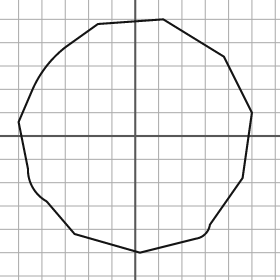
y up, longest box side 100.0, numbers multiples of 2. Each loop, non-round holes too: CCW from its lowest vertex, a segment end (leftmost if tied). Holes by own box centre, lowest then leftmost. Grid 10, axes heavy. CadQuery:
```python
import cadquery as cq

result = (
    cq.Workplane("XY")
    .moveTo(2.0, -50.0)
    .lineTo(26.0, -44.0)
    .threePointArc((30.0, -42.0), (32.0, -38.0))
    .lineTo(46.0, -18.0)
    .lineTo(50.0, 10.0)
    .lineTo(38.0, 34.0)
    .lineTo(12.0, 50.0)
    .lineTo(-16.0, 48.0)
    .lineTo(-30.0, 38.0)
    .threePointArc((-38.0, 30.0), (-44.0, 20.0))
    .lineTo(-50.0, 6.0)
    .lineTo(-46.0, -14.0)
    .threePointArc((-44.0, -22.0), (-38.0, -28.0))
    .lineTo(-26.0, -42.0)
    .close()
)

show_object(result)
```